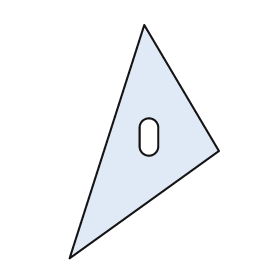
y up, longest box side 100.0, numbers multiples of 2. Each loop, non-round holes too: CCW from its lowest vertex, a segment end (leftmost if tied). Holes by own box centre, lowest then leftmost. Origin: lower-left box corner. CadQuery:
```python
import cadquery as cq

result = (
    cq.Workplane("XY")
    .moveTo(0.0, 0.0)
    .lineTo(64.0, 46.0)
    .lineTo(32.0, 100.0)
    .close()
    .moveTo(30.0, 48.0)
    .threePointArc((34.0, 44.0), (38.0, 48.0))
    .lineTo(38.0, 56.0)
    .threePointArc((34.0, 60.0), (30.0, 56.0))
    .close()
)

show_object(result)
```